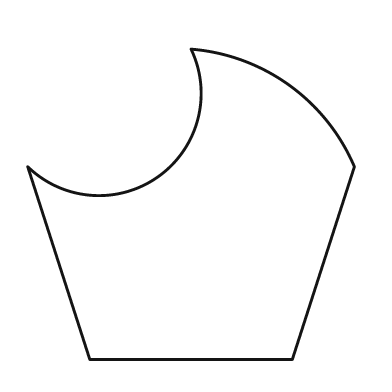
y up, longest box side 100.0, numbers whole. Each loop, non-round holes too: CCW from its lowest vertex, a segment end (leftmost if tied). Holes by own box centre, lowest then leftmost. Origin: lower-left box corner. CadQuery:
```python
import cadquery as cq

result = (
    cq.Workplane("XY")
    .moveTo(19.0, 0.0)
    .lineTo(81.0, 0.0)
    .lineTo(100.0, 59.0)
    .threePointArc((80.0, 84.0), (50.0, 95.0))
    .threePointArc((40.0, 56.0), (0.0, 59.0))
    .close()
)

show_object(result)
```